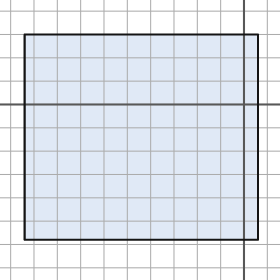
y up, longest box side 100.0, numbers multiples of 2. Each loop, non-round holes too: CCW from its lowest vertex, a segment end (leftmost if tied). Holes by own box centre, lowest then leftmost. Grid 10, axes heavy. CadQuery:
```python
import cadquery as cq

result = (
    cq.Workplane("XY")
    .moveTo(-94.0, -58.0)
    .lineTo(6.0, -58.0)
    .lineTo(6.0, 30.0)
    .lineTo(-94.0, 30.0)
    .close()
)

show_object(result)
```